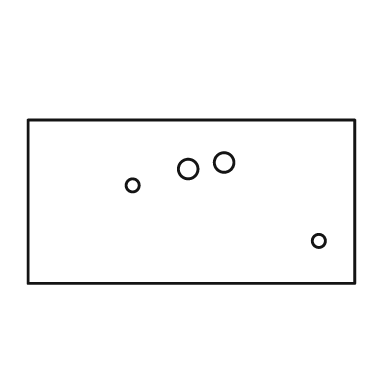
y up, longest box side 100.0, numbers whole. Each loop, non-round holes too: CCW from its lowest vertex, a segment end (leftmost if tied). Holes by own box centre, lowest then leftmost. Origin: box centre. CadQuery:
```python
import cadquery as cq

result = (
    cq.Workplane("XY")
    .moveTo(-50.0, -25.0)
    .lineTo(50.0, -25.0)
    .lineTo(50.0, 25.0)
    .lineTo(-50.0, 25.0)
    .close()
    .moveTo(39.0, -12.0)
    .circle(2.0)
    .moveTo(-18.0, 5.0)
    .circle(2.0)
    .moveTo(-1.0, 10.0)
    .circle(3.0)
    .moveTo(10.0, 12.0)
    .circle(3.0)
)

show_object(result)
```